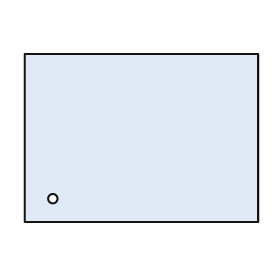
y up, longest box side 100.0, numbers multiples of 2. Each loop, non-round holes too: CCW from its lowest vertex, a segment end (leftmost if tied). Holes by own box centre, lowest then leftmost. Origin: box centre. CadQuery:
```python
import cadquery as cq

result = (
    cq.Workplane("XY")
    .moveTo(-50.0, -36.0)
    .lineTo(50.0, -36.0)
    .lineTo(50.0, 36.0)
    .lineTo(-50.0, 36.0)
    .close()
    .moveTo(-38.0, -26.0)
    .circle(2.0)
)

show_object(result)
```